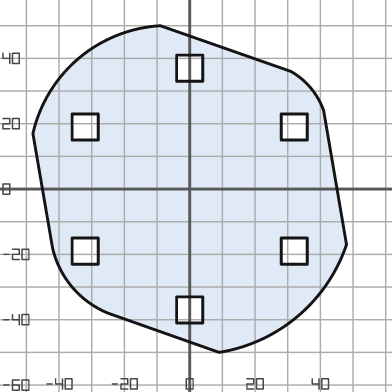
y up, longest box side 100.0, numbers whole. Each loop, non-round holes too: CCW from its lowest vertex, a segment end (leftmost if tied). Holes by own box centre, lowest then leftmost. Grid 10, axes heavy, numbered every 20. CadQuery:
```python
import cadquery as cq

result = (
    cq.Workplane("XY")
    .moveTo(9.0, -50.0)
    .threePointArc((33.0, -39.0), (48.0, -17.0))
    .lineTo(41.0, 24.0)
    .threePointArc((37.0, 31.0), (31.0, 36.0))
    .lineTo(-9.0, 50.0)
    .threePointArc((-34.0, 40.0), (-48.0, 17.0))
    .lineTo(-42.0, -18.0)
    .threePointArc((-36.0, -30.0), (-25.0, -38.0))
    .close()
    .moveTo(-4.0, -41.0)
    .lineTo(4.0, -41.0)
    .lineTo(4.0, -33.0)
    .lineTo(-4.0, -33.0)
    .close()
    .moveTo(-36.0, -23.0)
    .lineTo(-28.0, -23.0)
    .lineTo(-28.0, -15.0)
    .lineTo(-36.0, -15.0)
    .close()
    .moveTo(28.0, -23.0)
    .lineTo(36.0, -23.0)
    .lineTo(36.0, -15.0)
    .lineTo(28.0, -15.0)
    .close()
    .moveTo(-36.0, 15.0)
    .lineTo(-28.0, 15.0)
    .lineTo(-28.0, 23.0)
    .lineTo(-36.0, 23.0)
    .close()
    .moveTo(28.0, 15.0)
    .lineTo(36.0, 15.0)
    .lineTo(36.0, 23.0)
    .lineTo(28.0, 23.0)
    .close()
    .moveTo(-4.0, 33.0)
    .lineTo(4.0, 33.0)
    .lineTo(4.0, 41.0)
    .lineTo(-4.0, 41.0)
    .close()
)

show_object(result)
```